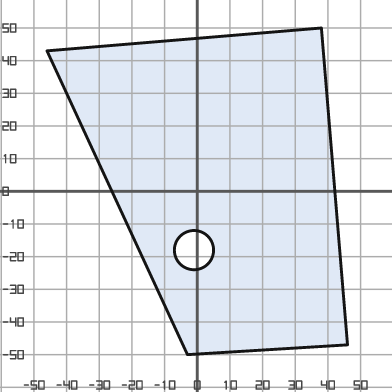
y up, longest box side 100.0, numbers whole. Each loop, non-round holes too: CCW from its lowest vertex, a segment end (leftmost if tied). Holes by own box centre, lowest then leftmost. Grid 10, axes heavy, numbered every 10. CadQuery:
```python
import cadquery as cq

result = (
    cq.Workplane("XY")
    .moveTo(-3.0, -50.0)
    .lineTo(46.0, -47.0)
    .lineTo(38.0, 50.0)
    .lineTo(-46.0, 43.0)
    .close()
    .moveTo(-1.0, -18.0)
    .circle(6.0)
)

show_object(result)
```